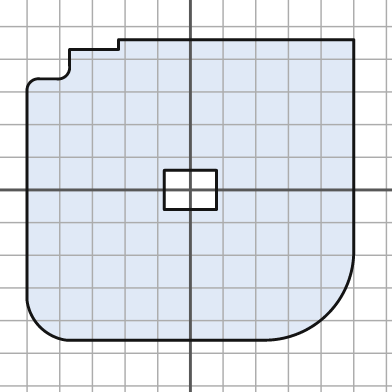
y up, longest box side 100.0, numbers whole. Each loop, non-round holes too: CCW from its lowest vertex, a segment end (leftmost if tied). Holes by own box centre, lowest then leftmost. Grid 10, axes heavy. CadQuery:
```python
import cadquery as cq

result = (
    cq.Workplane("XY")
    .moveTo(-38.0, -46.0)
    .lineTo(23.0, -46.0)
    .threePointArc((42.0, -38.0), (50.0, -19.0))
    .lineTo(50.0, 46.0)
    .lineTo(-22.0, 46.0)
    .lineTo(-22.0, 43.0)
    .lineTo(-37.0, 43.0)
    .lineTo(-37.0, 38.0)
    .threePointArc((-38.0, 35.0), (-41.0, 34.0))
    .lineTo(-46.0, 34.0)
    .threePointArc((-49.0, 33.0), (-50.0, 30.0))
    .lineTo(-50.0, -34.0)
    .threePointArc((-46.0, -42.0), (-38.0, -46.0))
    .close()
    .moveTo(-8.0, -6.0)
    .lineTo(8.0, -6.0)
    .lineTo(8.0, 6.0)
    .lineTo(-8.0, 6.0)
    .close()
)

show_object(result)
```